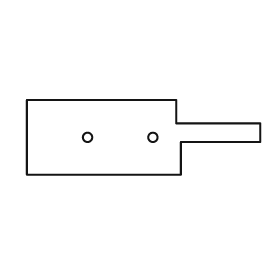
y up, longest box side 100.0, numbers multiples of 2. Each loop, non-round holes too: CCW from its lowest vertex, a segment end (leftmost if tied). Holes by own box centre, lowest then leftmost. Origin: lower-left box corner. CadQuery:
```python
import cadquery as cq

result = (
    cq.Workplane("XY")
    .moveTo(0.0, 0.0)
    .lineTo(66.0, 0.0)
    .lineTo(66.0, 14.0)
    .lineTo(100.0, 14.0)
    .lineTo(100.0, 22.0)
    .lineTo(64.0, 22.0)
    .lineTo(64.0, 32.0)
    .lineTo(0.0, 32.0)
    .close()
    .moveTo(26.0, 16.0)
    .circle(2.0)
    .moveTo(54.0, 16.0)
    .circle(2.0)
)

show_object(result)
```